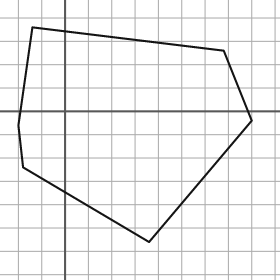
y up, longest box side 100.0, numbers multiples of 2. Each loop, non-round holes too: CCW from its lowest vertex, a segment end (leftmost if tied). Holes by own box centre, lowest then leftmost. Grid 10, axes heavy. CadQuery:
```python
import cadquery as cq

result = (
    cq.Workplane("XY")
    .moveTo(36.0, -56.0)
    .lineTo(80.0, -4.0)
    .lineTo(68.0, 26.0)
    .lineTo(-14.0, 36.0)
    .lineTo(-20.0, -6.0)
    .lineTo(-18.0, -24.0)
    .close()
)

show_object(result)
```